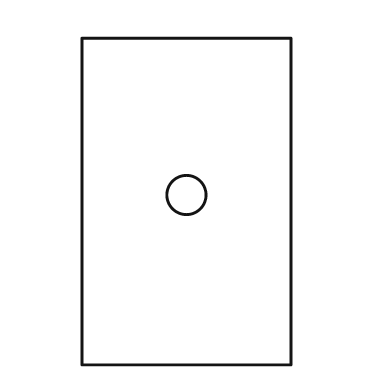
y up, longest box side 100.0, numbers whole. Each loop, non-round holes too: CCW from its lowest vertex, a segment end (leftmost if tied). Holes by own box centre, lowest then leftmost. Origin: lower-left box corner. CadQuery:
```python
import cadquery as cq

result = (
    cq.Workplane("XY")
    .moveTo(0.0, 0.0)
    .lineTo(64.0, 0.0)
    .lineTo(64.0, 100.0)
    .lineTo(0.0, 100.0)
    .close()
    .moveTo(32.0, 52.0)
    .circle(6.0)
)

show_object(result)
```